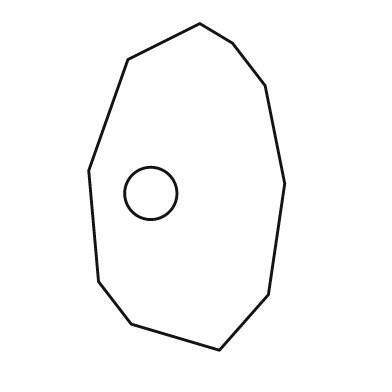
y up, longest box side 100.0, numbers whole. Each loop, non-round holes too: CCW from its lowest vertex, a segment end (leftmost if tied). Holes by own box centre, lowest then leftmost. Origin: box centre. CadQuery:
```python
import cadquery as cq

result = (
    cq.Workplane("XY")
    .moveTo(10.0, -50.0)
    .lineTo(25.0, -33.0)
    .lineTo(30.0, 1.0)
    .lineTo(24.0, 31.0)
    .lineTo(14.0, 44.0)
    .lineTo(4.0, 50.0)
    .lineTo(-18.0, 39.0)
    .lineTo(-30.0, 5.0)
    .lineTo(-27.0, -29.0)
    .lineTo(-17.0, -42.0)
    .close()
    .moveTo(-11.0, -2.0)
    .circle(8.0)
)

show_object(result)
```